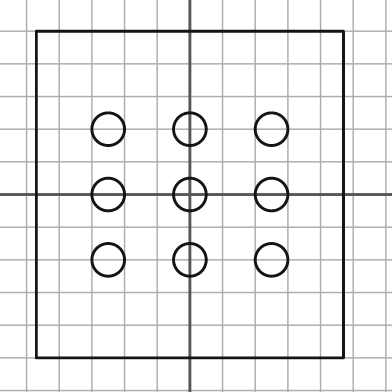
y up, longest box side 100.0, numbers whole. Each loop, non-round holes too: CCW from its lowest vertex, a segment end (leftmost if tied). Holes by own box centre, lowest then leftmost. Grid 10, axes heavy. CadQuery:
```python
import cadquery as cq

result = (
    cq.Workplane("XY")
    .moveTo(-47.0, -50.0)
    .lineTo(47.0, -50.0)
    .lineTo(47.0, 50.0)
    .lineTo(-47.0, 50.0)
    .close()
    .moveTo(-25.0, -20.0)
    .circle(5.0)
    .moveTo(0.0, -20.0)
    .circle(5.0)
    .moveTo(25.0, -20.0)
    .circle(5.0)
    .moveTo(-25.0, 0.0)
    .circle(5.0)
    .moveTo(0.0, 0.0)
    .circle(5.0)
    .moveTo(25.0, 0.0)
    .circle(5.0)
    .moveTo(-25.0, 20.0)
    .circle(5.0)
    .moveTo(0.0, 20.0)
    .circle(5.0)
    .moveTo(25.0, 20.0)
    .circle(5.0)
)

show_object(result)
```